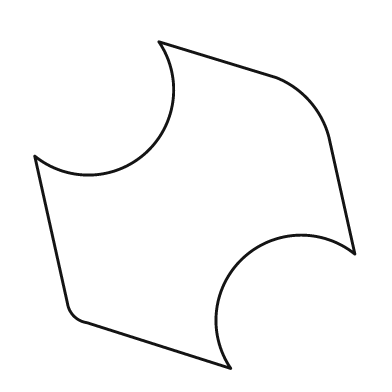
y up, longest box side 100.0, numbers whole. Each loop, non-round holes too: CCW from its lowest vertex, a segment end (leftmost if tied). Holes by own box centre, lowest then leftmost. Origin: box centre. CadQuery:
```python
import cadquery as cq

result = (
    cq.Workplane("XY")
    .moveTo(11.0, -50.0)
    .threePointArc((15.0, -16.0), (49.0, -15.0))
    .lineTo(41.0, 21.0)
    .threePointArc((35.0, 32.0), (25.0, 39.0))
    .lineTo(-11.0, 50.0)
    .threePointArc((-15.0, 16.0), (-49.0, 15.0))
    .lineTo(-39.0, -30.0)
    .threePointArc((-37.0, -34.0), (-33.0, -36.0))
    .close()
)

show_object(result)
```